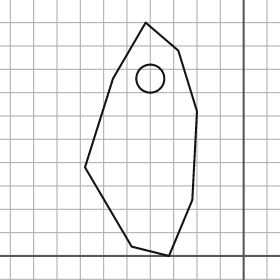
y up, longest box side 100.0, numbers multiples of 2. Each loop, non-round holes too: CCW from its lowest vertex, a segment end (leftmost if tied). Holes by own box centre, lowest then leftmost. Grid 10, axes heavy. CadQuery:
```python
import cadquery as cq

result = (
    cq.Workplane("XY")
    .moveTo(-32.0, 0.0)
    .lineTo(-22.0, 24.0)
    .lineTo(-20.0, 62.0)
    .lineTo(-28.0, 88.0)
    .lineTo(-42.0, 100.0)
    .lineTo(-56.0, 76.0)
    .lineTo(-68.0, 38.0)
    .lineTo(-48.0, 4.0)
    .close()
    .moveTo(-40.0, 76.0)
    .circle(6.0)
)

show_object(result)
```